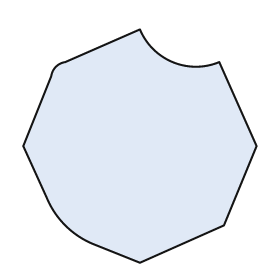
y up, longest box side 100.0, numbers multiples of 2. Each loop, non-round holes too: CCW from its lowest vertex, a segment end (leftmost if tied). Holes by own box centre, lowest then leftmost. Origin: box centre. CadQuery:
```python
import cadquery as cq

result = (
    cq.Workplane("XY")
    .moveTo(0.0, -50.0)
    .lineTo(36.0, -34.0)
    .lineTo(50.0, 0.0)
    .lineTo(34.0, 36.0)
    .threePointArc((14.0, 36.0), (0.0, 50.0))
    .lineTo(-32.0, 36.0)
    .threePointArc((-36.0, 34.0), (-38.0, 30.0))
    .lineTo(-50.0, 0.0)
    .lineTo(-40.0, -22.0)
    .threePointArc((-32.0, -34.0), (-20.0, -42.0))
    .close()
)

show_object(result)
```